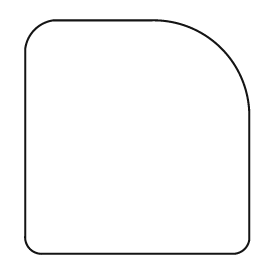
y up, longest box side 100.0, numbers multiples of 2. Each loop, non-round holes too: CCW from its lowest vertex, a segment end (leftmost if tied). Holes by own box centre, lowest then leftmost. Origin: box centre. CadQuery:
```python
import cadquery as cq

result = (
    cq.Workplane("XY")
    .moveTo(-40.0, -50.0)
    .lineTo(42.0, -50.0)
    .threePointArc((46.0, -48.0), (48.0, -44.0))
    .lineTo(48.0, 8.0)
    .threePointArc((36.0, 38.0), (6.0, 50.0))
    .lineTo(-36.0, 50.0)
    .threePointArc((-44.0, 46.0), (-48.0, 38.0))
    .lineTo(-48.0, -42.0)
    .threePointArc((-46.0, -48.0), (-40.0, -50.0))
    .close()
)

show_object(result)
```